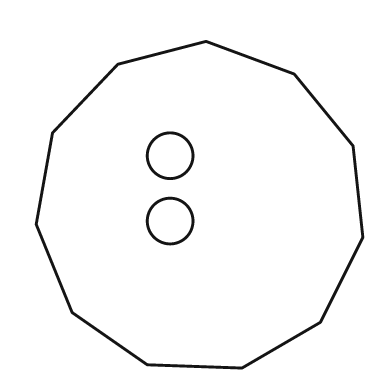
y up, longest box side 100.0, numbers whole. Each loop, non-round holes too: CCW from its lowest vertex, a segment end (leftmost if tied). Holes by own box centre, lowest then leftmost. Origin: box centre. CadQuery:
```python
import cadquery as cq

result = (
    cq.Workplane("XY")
    .moveTo(13.0, -50.0)
    .lineTo(37.0, -36.0)
    .lineTo(50.0, -10.0)
    .lineTo(47.0, 18.0)
    .lineTo(29.0, 40.0)
    .lineTo(2.0, 50.0)
    .lineTo(-25.0, 43.0)
    .lineTo(-45.0, 22.0)
    .lineTo(-50.0, -6.0)
    .lineTo(-39.0, -33.0)
    .lineTo(-16.0, -49.0)
    .close()
    .moveTo(-9.0, -5.0)
    .circle(7.0)
    .moveTo(-9.0, 15.0)
    .circle(7.0)
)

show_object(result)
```